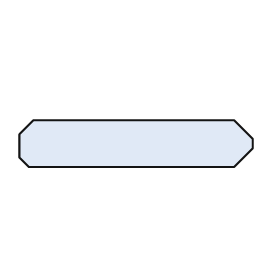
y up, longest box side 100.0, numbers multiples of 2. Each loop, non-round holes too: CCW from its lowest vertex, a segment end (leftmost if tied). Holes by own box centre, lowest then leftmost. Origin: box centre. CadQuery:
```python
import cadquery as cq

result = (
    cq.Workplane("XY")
    .moveTo(-46.0, -10.0)
    .lineTo(42.0, -10.0)
    .lineTo(50.0, -2.0)
    .lineTo(50.0, 2.0)
    .lineTo(42.0, 10.0)
    .lineTo(-44.0, 10.0)
    .lineTo(-50.0, 4.0)
    .lineTo(-50.0, -6.0)
    .close()
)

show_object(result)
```